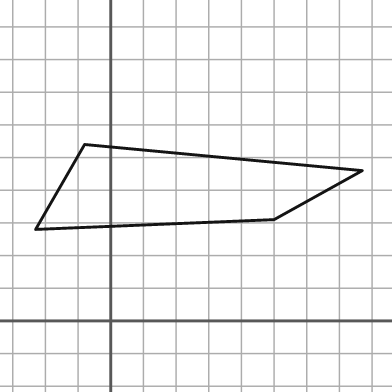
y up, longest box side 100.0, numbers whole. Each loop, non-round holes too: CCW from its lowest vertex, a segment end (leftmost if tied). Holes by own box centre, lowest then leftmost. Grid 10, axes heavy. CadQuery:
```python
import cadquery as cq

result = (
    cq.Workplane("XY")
    .moveTo(-23.0, 28.0)
    .lineTo(50.0, 31.0)
    .lineTo(77.0, 46.0)
    .lineTo(-8.0, 54.0)
    .close()
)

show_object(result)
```